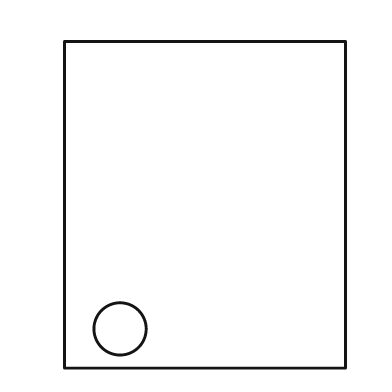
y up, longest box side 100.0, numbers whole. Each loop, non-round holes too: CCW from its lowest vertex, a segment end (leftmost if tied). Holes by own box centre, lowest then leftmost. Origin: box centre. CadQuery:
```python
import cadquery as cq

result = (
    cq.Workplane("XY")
    .moveTo(-43.0, -50.0)
    .lineTo(43.0, -50.0)
    .lineTo(43.0, 50.0)
    .lineTo(-43.0, 50.0)
    .close()
    .moveTo(-26.0, -38.0)
    .circle(8.0)
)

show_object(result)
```